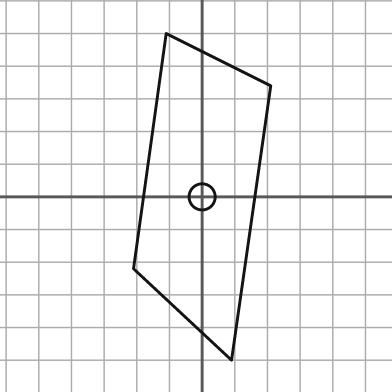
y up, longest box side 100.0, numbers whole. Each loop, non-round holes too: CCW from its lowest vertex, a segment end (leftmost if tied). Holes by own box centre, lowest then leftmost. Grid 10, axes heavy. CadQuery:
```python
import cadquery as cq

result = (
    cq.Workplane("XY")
    .moveTo(9.0, -50.0)
    .lineTo(21.0, 34.0)
    .lineTo(-11.0, 50.0)
    .lineTo(-21.0, -22.0)
    .close()
    .moveTo(0.0, 0.0)
    .circle(4.0)
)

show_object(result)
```